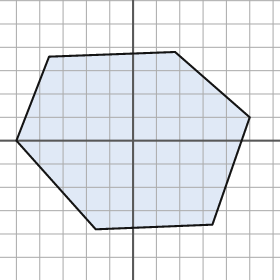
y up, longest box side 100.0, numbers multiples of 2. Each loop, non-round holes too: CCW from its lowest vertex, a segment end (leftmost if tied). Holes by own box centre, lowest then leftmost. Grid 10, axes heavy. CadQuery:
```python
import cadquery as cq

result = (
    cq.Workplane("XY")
    .moveTo(-16.0, -38.0)
    .lineTo(34.0, -36.0)
    .lineTo(50.0, 10.0)
    .lineTo(18.0, 38.0)
    .lineTo(-36.0, 36.0)
    .lineTo(-50.0, 0.0)
    .close()
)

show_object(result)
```